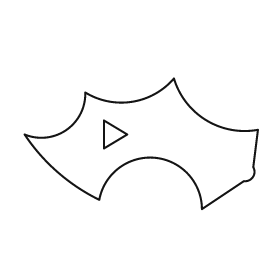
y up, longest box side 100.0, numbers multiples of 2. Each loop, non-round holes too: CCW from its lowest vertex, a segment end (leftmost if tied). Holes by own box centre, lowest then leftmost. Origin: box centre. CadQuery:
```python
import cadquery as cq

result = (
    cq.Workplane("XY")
    .moveTo(26.0, -28.0)
    .lineTo(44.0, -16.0)
    .threePointArc((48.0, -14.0), (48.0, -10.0))
    .lineTo(50.0, 6.0)
    .threePointArc((28.0, 10.0), (14.0, 28.0))
    .threePointArc((-4.0, 18.0), (-24.0, 22.0))
    .threePointArc((-32.0, 6.0), (-50.0, 4.0))
    .threePointArc((-36.0, -12.0), (-18.0, -24.0))
    .threePointArc((6.0, -6.0), (26.0, -28.0))
    .close()
    .moveTo(-16.0, -2.0)
    .lineTo(-6.0, 4.0)
    .lineTo(-16.0, 10.0)
    .close()
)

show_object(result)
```